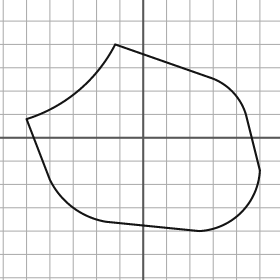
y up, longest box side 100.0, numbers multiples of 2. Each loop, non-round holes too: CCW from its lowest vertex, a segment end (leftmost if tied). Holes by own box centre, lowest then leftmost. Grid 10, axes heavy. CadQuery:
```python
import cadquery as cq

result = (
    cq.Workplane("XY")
    .moveTo(24.0, -40.0)
    .threePointArc((42.0, -32.0), (50.0, -14.0))
    .lineTo(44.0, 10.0)
    .threePointArc((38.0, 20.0), (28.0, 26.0))
    .lineTo(-12.0, 40.0)
    .threePointArc((-28.0, 20.0), (-50.0, 8.0))
    .lineTo(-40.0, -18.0)
    .threePointArc((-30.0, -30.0), (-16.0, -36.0))
    .close()
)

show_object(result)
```